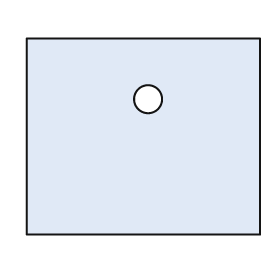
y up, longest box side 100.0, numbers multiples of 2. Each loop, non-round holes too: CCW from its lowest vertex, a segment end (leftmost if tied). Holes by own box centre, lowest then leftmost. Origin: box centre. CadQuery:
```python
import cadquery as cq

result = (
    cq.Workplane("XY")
    .moveTo(-50.0, -42.0)
    .lineTo(50.0, -42.0)
    .lineTo(50.0, 42.0)
    .lineTo(-50.0, 42.0)
    .close()
    .moveTo(2.0, 16.0)
    .circle(6.0)
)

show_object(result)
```